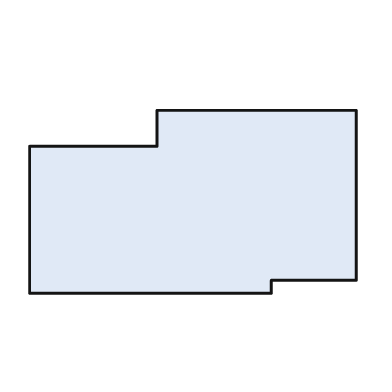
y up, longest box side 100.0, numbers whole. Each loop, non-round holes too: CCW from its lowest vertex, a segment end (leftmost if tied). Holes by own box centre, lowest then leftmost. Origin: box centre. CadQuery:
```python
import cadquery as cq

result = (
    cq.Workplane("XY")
    .moveTo(-50.0, -28.0)
    .lineTo(24.0, -28.0)
    .lineTo(24.0, -24.0)
    .lineTo(50.0, -24.0)
    .lineTo(50.0, 28.0)
    .lineTo(-11.0, 28.0)
    .lineTo(-11.0, 17.0)
    .lineTo(-50.0, 17.0)
    .close()
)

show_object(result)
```